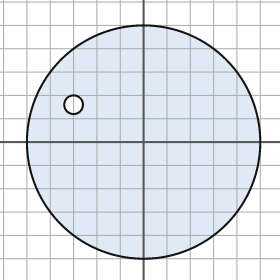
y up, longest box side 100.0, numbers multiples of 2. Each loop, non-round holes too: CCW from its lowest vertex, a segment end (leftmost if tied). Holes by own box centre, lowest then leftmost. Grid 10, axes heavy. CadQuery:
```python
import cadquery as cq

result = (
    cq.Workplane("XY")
    .moveTo(0.0, 0.0)
    .circle(50.0)
    .moveTo(-30.0, 16.0)
    .circle(4.0)
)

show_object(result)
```